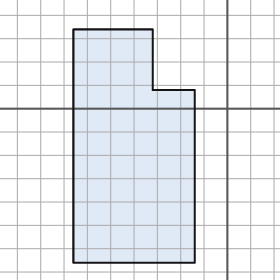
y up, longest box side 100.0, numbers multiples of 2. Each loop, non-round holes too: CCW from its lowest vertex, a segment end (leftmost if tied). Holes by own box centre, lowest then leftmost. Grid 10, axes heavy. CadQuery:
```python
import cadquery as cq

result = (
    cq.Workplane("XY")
    .moveTo(-66.0, -66.0)
    .lineTo(-14.0, -66.0)
    .lineTo(-14.0, 8.0)
    .lineTo(-32.0, 8.0)
    .lineTo(-32.0, 34.0)
    .lineTo(-66.0, 34.0)
    .close()
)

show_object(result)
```